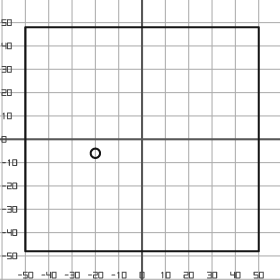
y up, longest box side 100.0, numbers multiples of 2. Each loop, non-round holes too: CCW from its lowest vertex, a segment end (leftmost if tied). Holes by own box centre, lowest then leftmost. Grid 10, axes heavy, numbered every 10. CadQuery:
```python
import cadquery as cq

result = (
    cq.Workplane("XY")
    .moveTo(-50.0, -48.0)
    .lineTo(50.0, -48.0)
    .lineTo(50.0, 48.0)
    .lineTo(-50.0, 48.0)
    .close()
    .moveTo(-20.0, -6.0)
    .circle(2.0)
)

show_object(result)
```